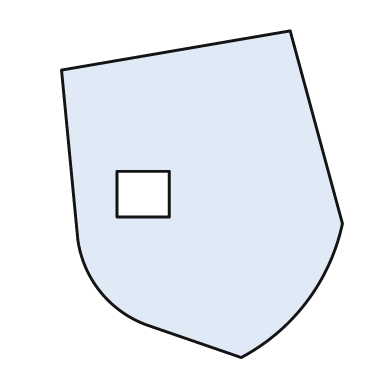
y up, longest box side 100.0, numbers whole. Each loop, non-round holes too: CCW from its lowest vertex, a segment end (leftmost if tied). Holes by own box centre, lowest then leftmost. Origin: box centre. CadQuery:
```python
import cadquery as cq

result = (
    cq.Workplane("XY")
    .moveTo(12.0, -50.0)
    .threePointArc((32.0, -33.0), (43.0, -9.0))
    .lineTo(27.0, 50.0)
    .lineTo(-43.0, 38.0)
    .lineTo(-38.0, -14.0)
    .threePointArc((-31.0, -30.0), (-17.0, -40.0))
    .close()
    .moveTo(-26.0, -7.0)
    .lineTo(-10.0, -7.0)
    .lineTo(-10.0, 7.0)
    .lineTo(-26.0, 7.0)
    .close()
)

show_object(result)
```